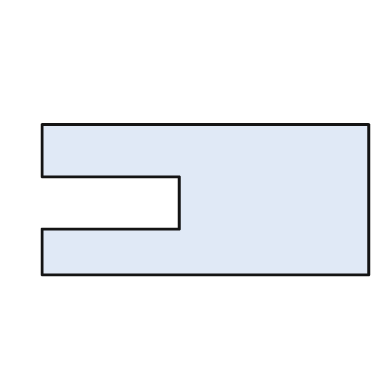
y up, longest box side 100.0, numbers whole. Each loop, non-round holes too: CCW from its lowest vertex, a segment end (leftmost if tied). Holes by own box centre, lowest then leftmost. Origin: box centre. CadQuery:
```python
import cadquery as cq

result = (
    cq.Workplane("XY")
    .moveTo(-50.0, -23.0)
    .lineTo(50.0, -23.0)
    .lineTo(50.0, 23.0)
    .lineTo(-50.0, 23.0)
    .lineTo(-50.0, 7.0)
    .lineTo(-8.0, 7.0)
    .lineTo(-8.0, -9.0)
    .lineTo(-50.0, -9.0)
    .close()
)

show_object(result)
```